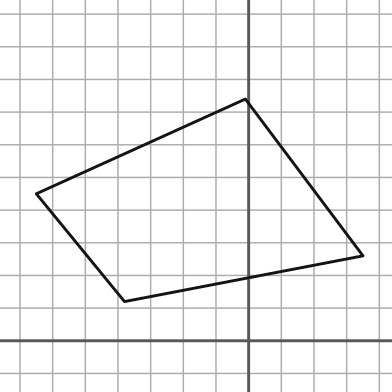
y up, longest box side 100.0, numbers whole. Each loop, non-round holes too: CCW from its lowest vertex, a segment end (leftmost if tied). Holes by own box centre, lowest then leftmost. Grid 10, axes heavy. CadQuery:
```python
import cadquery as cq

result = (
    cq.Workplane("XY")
    .moveTo(-38.0, 12.0)
    .lineTo(35.0, 26.0)
    .lineTo(-1.0, 74.0)
    .lineTo(-65.0, 45.0)
    .close()
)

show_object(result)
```